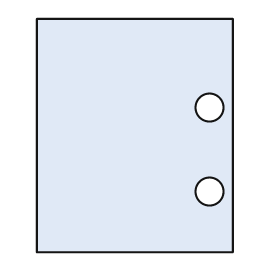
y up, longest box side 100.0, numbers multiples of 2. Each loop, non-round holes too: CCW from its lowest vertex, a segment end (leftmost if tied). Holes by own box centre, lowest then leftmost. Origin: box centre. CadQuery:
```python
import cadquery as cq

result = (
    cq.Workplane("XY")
    .moveTo(-42.0, -50.0)
    .lineTo(42.0, -50.0)
    .lineTo(42.0, 50.0)
    .lineTo(-42.0, 50.0)
    .close()
    .moveTo(32.0, -24.0)
    .circle(6.0)
    .moveTo(32.0, 12.0)
    .circle(6.0)
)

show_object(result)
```